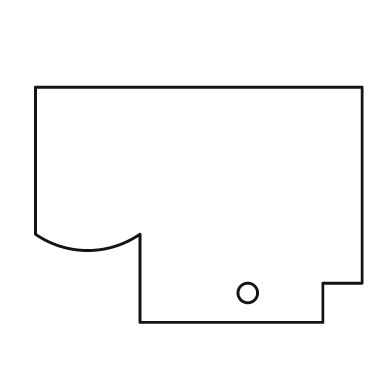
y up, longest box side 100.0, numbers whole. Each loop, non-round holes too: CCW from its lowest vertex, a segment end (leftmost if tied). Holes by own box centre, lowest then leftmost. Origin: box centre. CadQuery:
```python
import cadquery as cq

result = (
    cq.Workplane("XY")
    .moveTo(-18.0, -36.0)
    .lineTo(38.0, -36.0)
    .lineTo(38.0, -24.0)
    .lineTo(50.0, -24.0)
    .lineTo(50.0, 36.0)
    .lineTo(-50.0, 36.0)
    .lineTo(-50.0, -9.0)
    .threePointArc((-34.0, -14.0), (-18.0, -9.0))
    .close()
    .moveTo(15.0, -27.0)
    .circle(3.0)
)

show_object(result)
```